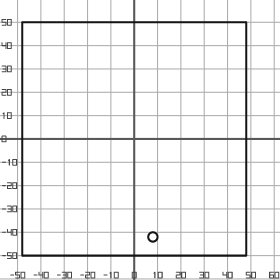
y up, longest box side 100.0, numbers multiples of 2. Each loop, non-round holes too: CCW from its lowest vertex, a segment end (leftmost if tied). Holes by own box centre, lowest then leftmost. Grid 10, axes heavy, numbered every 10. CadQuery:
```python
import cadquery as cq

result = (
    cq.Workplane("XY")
    .moveTo(-48.0, -50.0)
    .lineTo(48.0, -50.0)
    .lineTo(48.0, 50.0)
    .lineTo(-48.0, 50.0)
    .close()
    .moveTo(8.0, -42.0)
    .circle(2.0)
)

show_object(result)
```